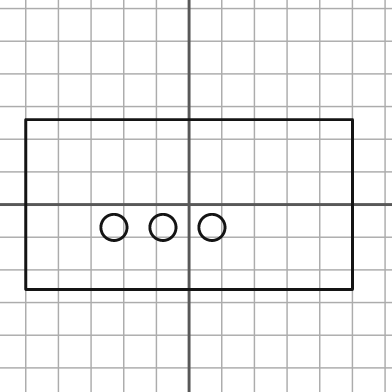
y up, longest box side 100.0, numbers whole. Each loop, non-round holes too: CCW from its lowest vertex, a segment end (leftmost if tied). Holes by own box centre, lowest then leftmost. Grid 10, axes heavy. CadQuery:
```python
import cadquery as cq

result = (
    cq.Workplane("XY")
    .moveTo(-50.0, -26.0)
    .lineTo(50.0, -26.0)
    .lineTo(50.0, 26.0)
    .lineTo(-50.0, 26.0)
    .close()
    .moveTo(-23.0, -7.0)
    .circle(4.0)
    .moveTo(-8.0, -7.0)
    .circle(4.0)
    .moveTo(7.0, -7.0)
    .circle(4.0)
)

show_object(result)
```